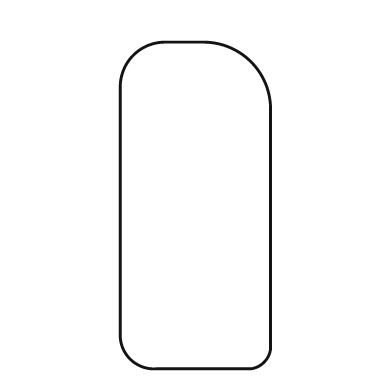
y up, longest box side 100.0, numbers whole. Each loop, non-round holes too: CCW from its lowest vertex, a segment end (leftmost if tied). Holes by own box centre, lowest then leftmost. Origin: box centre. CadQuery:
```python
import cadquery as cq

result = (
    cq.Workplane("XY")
    .moveTo(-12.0, -50.0)
    .lineTo(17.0, -50.0)
    .threePointArc((21.0, -48.0), (23.0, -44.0))
    .lineTo(23.0, 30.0)
    .threePointArc((17.0, 44.0), (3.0, 50.0))
    .lineTo(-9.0, 50.0)
    .threePointArc((-19.0, 46.0), (-23.0, 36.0))
    .lineTo(-23.0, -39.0)
    .threePointArc((-20.0, -47.0), (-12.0, -50.0))
    .close()
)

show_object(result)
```